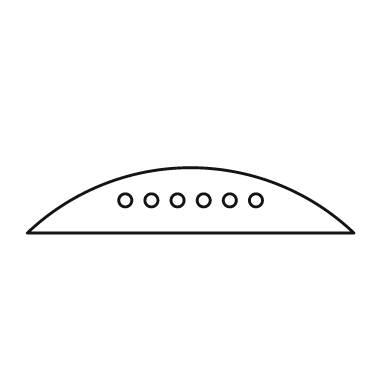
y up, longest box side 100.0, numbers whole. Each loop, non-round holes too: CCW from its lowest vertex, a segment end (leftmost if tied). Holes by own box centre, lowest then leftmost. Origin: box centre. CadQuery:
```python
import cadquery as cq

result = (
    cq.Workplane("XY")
    .moveTo(-50.0, -10.0)
    .lineTo(50.0, -10.0)
    .threePointArc((0.0, 10.0), (-50.0, -10.0))
    .close()
    .moveTo(-20.0, 0.0)
    .circle(2.0)
    .moveTo(-12.0, 0.0)
    .circle(2.0)
    .moveTo(-4.0, 0.0)
    .circle(2.0)
    .moveTo(4.0, 0.0)
    .circle(2.0)
    .moveTo(12.0, 0.0)
    .circle(2.0)
    .moveTo(20.0, 0.0)
    .circle(2.0)
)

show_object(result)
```